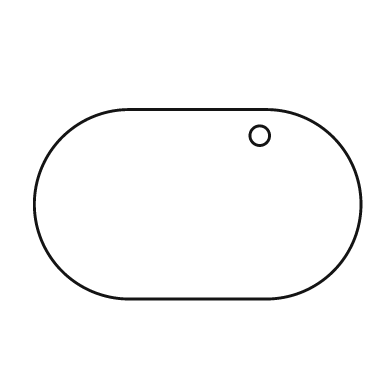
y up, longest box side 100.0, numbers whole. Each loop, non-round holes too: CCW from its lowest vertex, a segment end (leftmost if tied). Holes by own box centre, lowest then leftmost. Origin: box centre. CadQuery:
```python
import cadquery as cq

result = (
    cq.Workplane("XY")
    .moveTo(-21.0, -29.0)
    .lineTo(21.0, -29.0)
    .threePointArc((50.0, 0.0), (21.0, 29.0))
    .lineTo(-21.0, 29.0)
    .threePointArc((-50.0, 0.0), (-21.0, -29.0))
    .close()
    .moveTo(19.0, 21.0)
    .circle(3.0)
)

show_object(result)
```